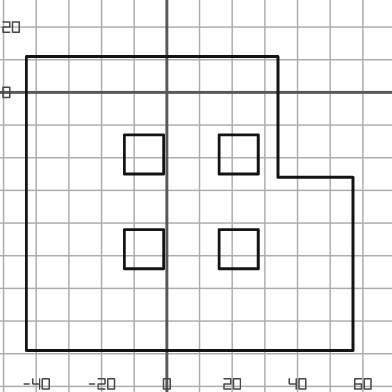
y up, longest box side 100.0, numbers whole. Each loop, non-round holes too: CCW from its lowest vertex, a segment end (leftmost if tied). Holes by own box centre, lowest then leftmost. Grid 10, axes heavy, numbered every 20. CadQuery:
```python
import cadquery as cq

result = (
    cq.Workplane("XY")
    .moveTo(-43.0, -79.0)
    .lineTo(57.0, -79.0)
    .lineTo(57.0, -26.0)
    .lineTo(34.0, -26.0)
    .lineTo(34.0, 11.0)
    .lineTo(-43.0, 11.0)
    .close()
    .moveTo(-13.0, -54.0)
    .lineTo(-1.0, -54.0)
    .lineTo(-1.0, -42.0)
    .lineTo(-13.0, -42.0)
    .close()
    .moveTo(16.0, -54.0)
    .lineTo(28.0, -54.0)
    .lineTo(28.0, -42.0)
    .lineTo(16.0, -42.0)
    .close()
    .moveTo(-13.0, -25.0)
    .lineTo(-1.0, -25.0)
    .lineTo(-1.0, -13.0)
    .lineTo(-13.0, -13.0)
    .close()
    .moveTo(16.0, -25.0)
    .lineTo(28.0, -25.0)
    .lineTo(28.0, -13.0)
    .lineTo(16.0, -13.0)
    .close()
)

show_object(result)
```